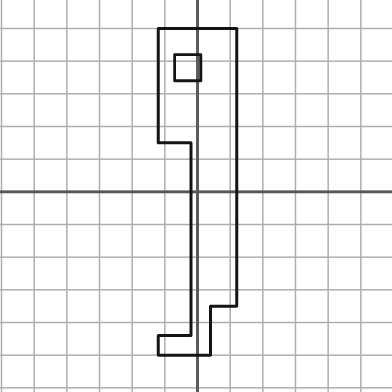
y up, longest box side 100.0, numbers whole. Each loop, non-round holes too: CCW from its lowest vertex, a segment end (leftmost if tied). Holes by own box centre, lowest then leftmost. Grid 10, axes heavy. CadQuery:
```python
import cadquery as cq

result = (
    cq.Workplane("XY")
    .moveTo(-12.0, -50.0)
    .lineTo(4.0, -50.0)
    .lineTo(4.0, -35.0)
    .lineTo(12.0, -35.0)
    .lineTo(12.0, 50.0)
    .lineTo(-12.0, 50.0)
    .lineTo(-12.0, 15.0)
    .lineTo(-2.0, 15.0)
    .lineTo(-2.0, -44.0)
    .lineTo(-12.0, -44.0)
    .close()
    .moveTo(-7.0, 34.0)
    .lineTo(1.0, 34.0)
    .lineTo(1.0, 42.0)
    .lineTo(-7.0, 42.0)
    .close()
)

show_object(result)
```